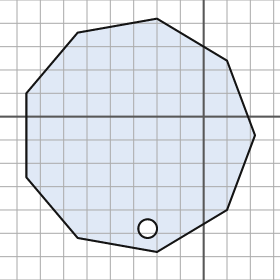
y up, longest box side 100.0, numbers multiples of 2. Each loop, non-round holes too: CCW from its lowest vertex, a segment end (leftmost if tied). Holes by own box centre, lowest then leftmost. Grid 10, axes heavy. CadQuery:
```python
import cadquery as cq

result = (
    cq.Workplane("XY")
    .moveTo(-20.0, -58.0)
    .lineTo(10.0, -40.0)
    .lineTo(22.0, -8.0)
    .lineTo(10.0, 24.0)
    .lineTo(-20.0, 42.0)
    .lineTo(-54.0, 36.0)
    .lineTo(-76.0, 10.0)
    .lineTo(-76.0, -26.0)
    .lineTo(-54.0, -52.0)
    .close()
    .moveTo(-24.0, -48.0)
    .circle(4.0)
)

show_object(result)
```